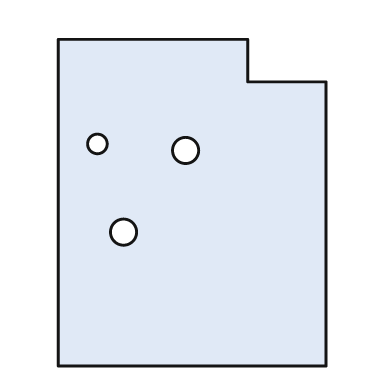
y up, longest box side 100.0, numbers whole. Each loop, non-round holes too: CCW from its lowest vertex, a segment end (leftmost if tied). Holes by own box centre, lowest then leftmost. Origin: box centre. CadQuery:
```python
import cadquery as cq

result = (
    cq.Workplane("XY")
    .moveTo(-41.0, -50.0)
    .lineTo(41.0, -50.0)
    .lineTo(41.0, 37.0)
    .lineTo(17.0, 37.0)
    .lineTo(17.0, 50.0)
    .lineTo(-41.0, 50.0)
    .close()
    .moveTo(-21.0, -9.0)
    .circle(4.0)
    .moveTo(-2.0, 16.0)
    .circle(4.0)
    .moveTo(-29.0, 18.0)
    .circle(3.0)
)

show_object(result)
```